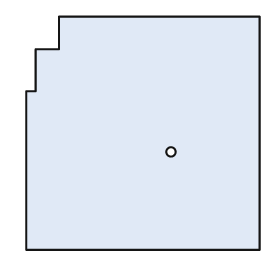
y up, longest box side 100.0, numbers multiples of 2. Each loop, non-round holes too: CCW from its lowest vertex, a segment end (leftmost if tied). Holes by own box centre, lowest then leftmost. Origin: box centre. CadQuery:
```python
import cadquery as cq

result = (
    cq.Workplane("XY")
    .moveTo(-50.0, -50.0)
    .lineTo(50.0, -50.0)
    .lineTo(50.0, 50.0)
    .lineTo(-36.0, 50.0)
    .lineTo(-36.0, 36.0)
    .lineTo(-46.0, 36.0)
    .lineTo(-46.0, 18.0)
    .lineTo(-50.0, 18.0)
    .close()
    .moveTo(12.0, -8.0)
    .circle(2.0)
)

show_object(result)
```